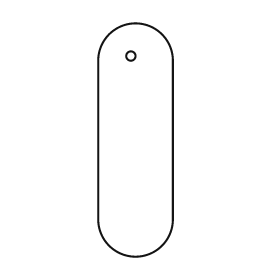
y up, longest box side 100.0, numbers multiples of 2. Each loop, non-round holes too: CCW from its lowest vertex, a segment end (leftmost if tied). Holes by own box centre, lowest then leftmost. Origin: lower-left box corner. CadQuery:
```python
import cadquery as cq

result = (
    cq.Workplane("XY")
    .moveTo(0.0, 16.0)
    .threePointArc((16.0, 0.0), (32.0, 16.0))
    .lineTo(32.0, 84.0)
    .threePointArc((16.0, 100.0), (0.0, 84.0))
    .close()
    .moveTo(14.0, 86.0)
    .circle(2.0)
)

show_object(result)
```